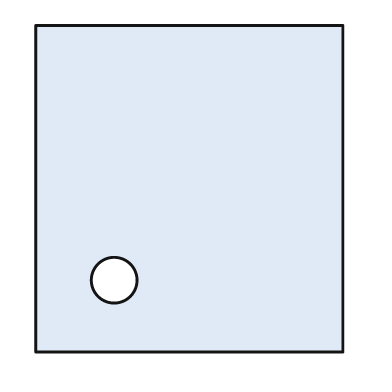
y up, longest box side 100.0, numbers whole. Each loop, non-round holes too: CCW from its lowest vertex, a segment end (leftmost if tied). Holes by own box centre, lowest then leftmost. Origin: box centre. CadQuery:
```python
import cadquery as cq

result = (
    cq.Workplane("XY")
    .moveTo(-47.0, -50.0)
    .lineTo(47.0, -50.0)
    .lineTo(47.0, 50.0)
    .lineTo(-47.0, 50.0)
    .close()
    .moveTo(-23.0, -28.0)
    .circle(7.0)
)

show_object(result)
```